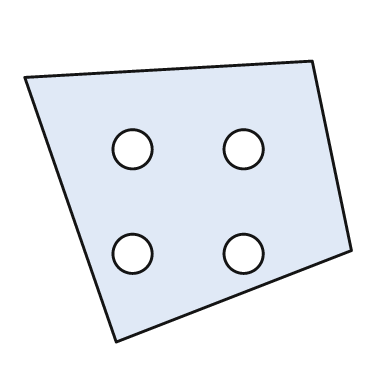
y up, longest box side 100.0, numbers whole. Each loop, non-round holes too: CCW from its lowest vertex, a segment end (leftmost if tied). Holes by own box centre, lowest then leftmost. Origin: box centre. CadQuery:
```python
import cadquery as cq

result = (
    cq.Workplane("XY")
    .moveTo(-22.0, -43.0)
    .lineTo(50.0, -15.0)
    .lineTo(38.0, 43.0)
    .lineTo(-50.0, 38.0)
    .close()
    .moveTo(-17.0, -16.0)
    .circle(6.0)
    .moveTo(17.0, -16.0)
    .circle(6.0)
    .moveTo(-17.0, 16.0)
    .circle(6.0)
    .moveTo(17.0, 16.0)
    .circle(6.0)
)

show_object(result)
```